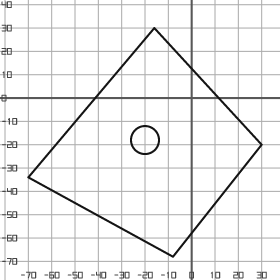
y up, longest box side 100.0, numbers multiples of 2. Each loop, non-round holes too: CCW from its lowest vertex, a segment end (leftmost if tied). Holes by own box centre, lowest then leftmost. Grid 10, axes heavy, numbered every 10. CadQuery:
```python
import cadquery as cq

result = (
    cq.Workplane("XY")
    .moveTo(-8.0, -68.0)
    .lineTo(30.0, -20.0)
    .lineTo(-16.0, 30.0)
    .lineTo(-70.0, -34.0)
    .close()
    .moveTo(-20.0, -18.0)
    .circle(6.0)
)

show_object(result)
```